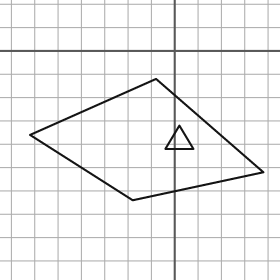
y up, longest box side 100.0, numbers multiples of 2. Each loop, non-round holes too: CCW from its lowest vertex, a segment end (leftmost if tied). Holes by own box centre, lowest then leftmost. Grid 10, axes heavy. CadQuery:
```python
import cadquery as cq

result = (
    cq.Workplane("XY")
    .moveTo(-18.0, -64.0)
    .lineTo(38.0, -52.0)
    .lineTo(-8.0, -12.0)
    .lineTo(-62.0, -36.0)
    .close()
    .moveTo(-4.0, -42.0)
    .lineTo(8.0, -42.0)
    .lineTo(2.0, -32.0)
    .close()
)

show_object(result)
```